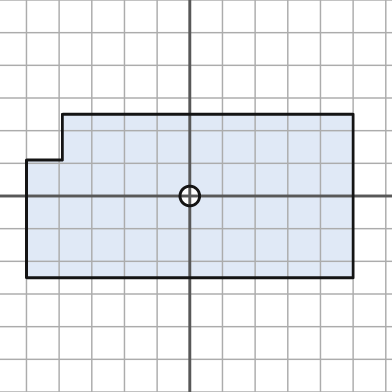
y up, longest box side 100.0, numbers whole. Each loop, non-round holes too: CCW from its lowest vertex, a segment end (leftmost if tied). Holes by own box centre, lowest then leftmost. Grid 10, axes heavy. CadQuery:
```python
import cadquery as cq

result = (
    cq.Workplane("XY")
    .moveTo(-50.0, -25.0)
    .lineTo(50.0, -25.0)
    .lineTo(50.0, 25.0)
    .lineTo(-39.0, 25.0)
    .lineTo(-39.0, 11.0)
    .lineTo(-50.0, 11.0)
    .close()
    .moveTo(0.0, 0.0)
    .circle(3.0)
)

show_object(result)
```